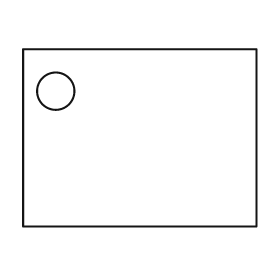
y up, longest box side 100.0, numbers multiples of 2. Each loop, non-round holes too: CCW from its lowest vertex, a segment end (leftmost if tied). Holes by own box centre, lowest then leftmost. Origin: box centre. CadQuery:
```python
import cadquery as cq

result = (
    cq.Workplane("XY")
    .moveTo(-50.0, -38.0)
    .lineTo(50.0, -38.0)
    .lineTo(50.0, 38.0)
    .lineTo(-50.0, 38.0)
    .close()
    .moveTo(-36.0, 20.0)
    .circle(8.0)
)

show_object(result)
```